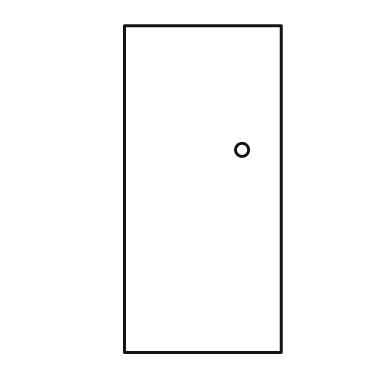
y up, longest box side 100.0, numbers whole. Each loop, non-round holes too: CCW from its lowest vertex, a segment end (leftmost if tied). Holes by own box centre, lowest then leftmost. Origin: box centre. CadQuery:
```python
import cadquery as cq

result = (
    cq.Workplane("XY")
    .moveTo(-24.0, -50.0)
    .lineTo(24.0, -50.0)
    .lineTo(24.0, 50.0)
    .lineTo(-24.0, 50.0)
    .close()
    .moveTo(12.0, 12.0)
    .circle(2.0)
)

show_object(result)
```